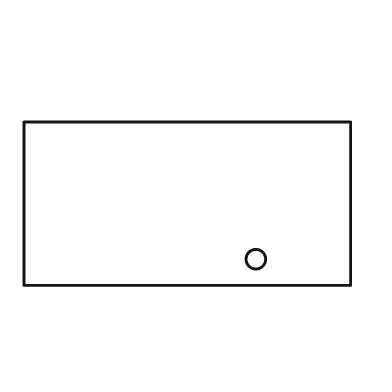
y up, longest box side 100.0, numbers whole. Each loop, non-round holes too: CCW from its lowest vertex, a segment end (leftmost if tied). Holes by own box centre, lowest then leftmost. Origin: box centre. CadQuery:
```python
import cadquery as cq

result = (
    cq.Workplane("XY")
    .moveTo(-50.0, -25.0)
    .lineTo(50.0, -25.0)
    .lineTo(50.0, 25.0)
    .lineTo(-50.0, 25.0)
    .close()
    .moveTo(21.0, -17.0)
    .circle(3.0)
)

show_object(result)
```